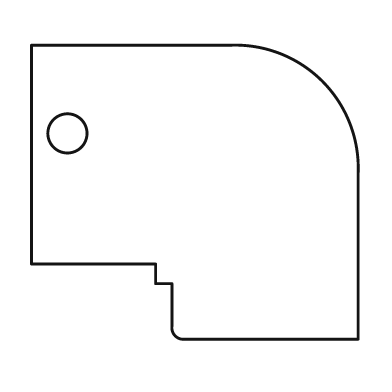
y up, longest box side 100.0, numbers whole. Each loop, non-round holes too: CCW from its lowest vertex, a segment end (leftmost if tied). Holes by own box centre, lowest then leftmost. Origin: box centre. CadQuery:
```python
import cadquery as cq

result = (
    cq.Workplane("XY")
    .moveTo(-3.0, -45.0)
    .lineTo(50.0, -45.0)
    .lineTo(50.0, 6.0)
    .threePointArc((39.0, 34.0), (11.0, 45.0))
    .lineTo(-50.0, 45.0)
    .lineTo(-50.0, -22.0)
    .lineTo(-12.0, -22.0)
    .lineTo(-12.0, -28.0)
    .lineTo(-7.0, -28.0)
    .lineTo(-7.0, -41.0)
    .threePointArc((-6.0, -44.0), (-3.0, -45.0))
    .close()
    .moveTo(-39.0, 18.0)
    .circle(6.0)
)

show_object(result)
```